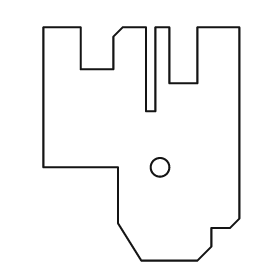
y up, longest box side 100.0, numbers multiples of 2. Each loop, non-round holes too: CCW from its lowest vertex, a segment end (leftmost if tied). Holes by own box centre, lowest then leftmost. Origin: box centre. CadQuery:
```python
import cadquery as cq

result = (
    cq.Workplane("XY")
    .moveTo(0.0, -50.0)
    .lineTo(24.0, -50.0)
    .lineTo(30.0, -44.0)
    .lineTo(30.0, -36.0)
    .lineTo(38.0, -36.0)
    .lineTo(42.0, -32.0)
    .lineTo(42.0, 50.0)
    .lineTo(24.0, 50.0)
    .lineTo(24.0, 26.0)
    .lineTo(12.0, 26.0)
    .lineTo(12.0, 50.0)
    .lineTo(6.0, 50.0)
    .lineTo(6.0, 14.0)
    .lineTo(2.0, 14.0)
    .lineTo(2.0, 50.0)
    .lineTo(-8.0, 50.0)
    .lineTo(-12.0, 46.0)
    .lineTo(-12.0, 32.0)
    .lineTo(-26.0, 32.0)
    .lineTo(-26.0, 50.0)
    .lineTo(-42.0, 50.0)
    .lineTo(-42.0, -10.0)
    .lineTo(-10.0, -10.0)
    .lineTo(-10.0, -34.0)
    .close()
    .moveTo(8.0, -10.0)
    .circle(4.0)
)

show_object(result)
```